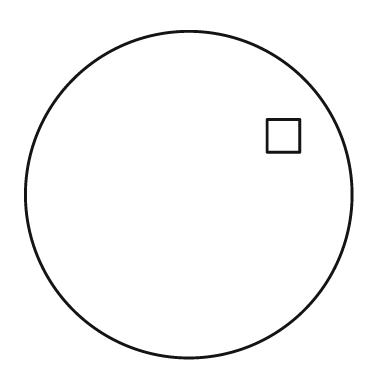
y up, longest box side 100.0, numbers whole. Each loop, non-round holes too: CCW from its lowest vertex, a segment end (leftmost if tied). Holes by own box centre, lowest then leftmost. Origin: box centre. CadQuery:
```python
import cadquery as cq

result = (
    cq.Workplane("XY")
    .moveTo(0.0, 0.0)
    .circle(50.0)
    .moveTo(24.0, 13.0)
    .lineTo(34.0, 13.0)
    .lineTo(34.0, 23.0)
    .lineTo(24.0, 23.0)
    .close()
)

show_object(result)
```